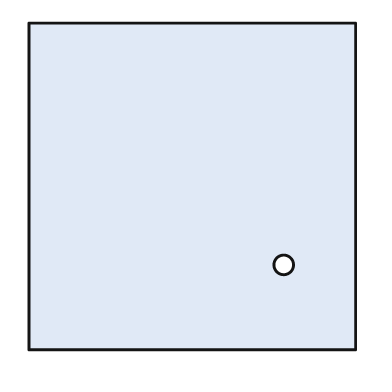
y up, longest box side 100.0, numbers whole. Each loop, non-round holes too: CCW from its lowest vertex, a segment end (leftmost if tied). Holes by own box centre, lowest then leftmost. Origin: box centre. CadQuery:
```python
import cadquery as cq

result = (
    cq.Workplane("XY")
    .moveTo(-50.0, -50.0)
    .lineTo(50.0, -50.0)
    .lineTo(50.0, 50.0)
    .lineTo(-50.0, 50.0)
    .close()
    .moveTo(28.0, -24.0)
    .circle(3.0)
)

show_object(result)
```